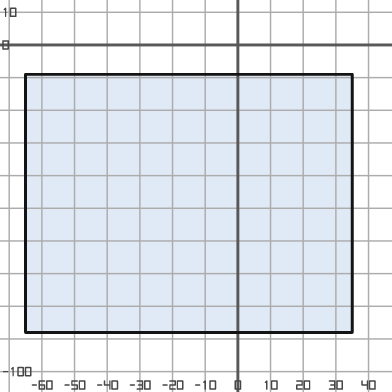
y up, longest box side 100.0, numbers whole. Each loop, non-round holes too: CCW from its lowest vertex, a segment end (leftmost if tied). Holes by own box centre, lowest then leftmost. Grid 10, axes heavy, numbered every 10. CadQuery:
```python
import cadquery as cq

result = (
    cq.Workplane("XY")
    .moveTo(-65.0, -88.0)
    .lineTo(35.0, -88.0)
    .lineTo(35.0, -9.0)
    .lineTo(-65.0, -9.0)
    .close()
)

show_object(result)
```